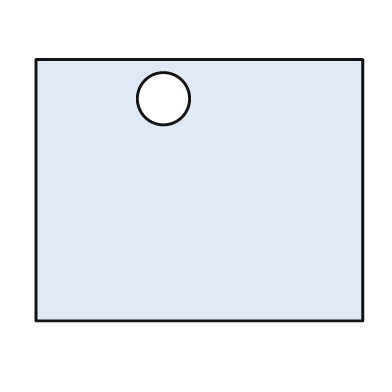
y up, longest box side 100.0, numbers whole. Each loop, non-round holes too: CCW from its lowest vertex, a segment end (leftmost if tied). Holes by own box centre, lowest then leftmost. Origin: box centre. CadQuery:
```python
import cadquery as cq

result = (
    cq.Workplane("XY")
    .moveTo(-50.0, -40.0)
    .lineTo(50.0, -40.0)
    .lineTo(50.0, 40.0)
    .lineTo(-50.0, 40.0)
    .close()
    .moveTo(-11.0, 28.0)
    .circle(8.0)
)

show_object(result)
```